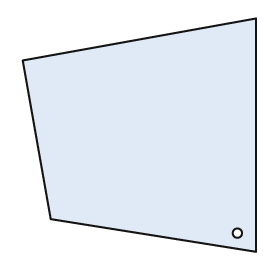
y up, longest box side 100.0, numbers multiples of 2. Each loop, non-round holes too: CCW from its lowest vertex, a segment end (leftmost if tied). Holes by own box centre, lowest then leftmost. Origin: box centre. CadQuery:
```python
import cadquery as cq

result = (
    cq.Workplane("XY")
    .moveTo(50.0, -50.0)
    .lineTo(50.0, 50.0)
    .lineTo(-50.0, 32.0)
    .lineTo(-38.0, -36.0)
    .close()
    .moveTo(42.0, -42.0)
    .circle(2.0)
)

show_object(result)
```